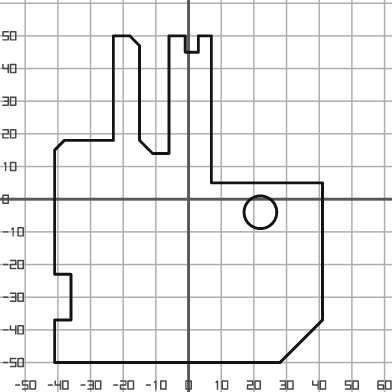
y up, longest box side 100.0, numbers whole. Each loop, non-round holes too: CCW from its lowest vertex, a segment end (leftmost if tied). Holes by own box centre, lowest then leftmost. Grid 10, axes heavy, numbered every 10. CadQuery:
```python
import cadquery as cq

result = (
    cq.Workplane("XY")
    .moveTo(-41.0, -50.0)
    .lineTo(28.0, -50.0)
    .lineTo(41.0, -37.0)
    .lineTo(41.0, 5.0)
    .lineTo(7.0, 5.0)
    .lineTo(7.0, 50.0)
    .lineTo(3.0, 50.0)
    .lineTo(3.0, 45.0)
    .lineTo(-1.0, 45.0)
    .lineTo(-1.0, 50.0)
    .lineTo(-6.0, 50.0)
    .lineTo(-6.0, 14.0)
    .lineTo(-11.0, 14.0)
    .lineTo(-15.0, 18.0)
    .lineTo(-15.0, 47.0)
    .lineTo(-18.0, 50.0)
    .lineTo(-23.0, 50.0)
    .lineTo(-23.0, 18.0)
    .lineTo(-38.0, 18.0)
    .lineTo(-41.0, 15.0)
    .lineTo(-41.0, -23.0)
    .lineTo(-36.0, -23.0)
    .lineTo(-36.0, -37.0)
    .lineTo(-41.0, -37.0)
    .close()
    .moveTo(22.0, -4.0)
    .circle(5.0)
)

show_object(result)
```